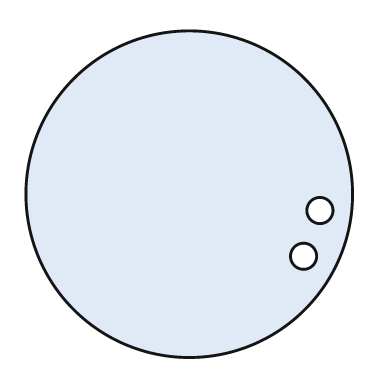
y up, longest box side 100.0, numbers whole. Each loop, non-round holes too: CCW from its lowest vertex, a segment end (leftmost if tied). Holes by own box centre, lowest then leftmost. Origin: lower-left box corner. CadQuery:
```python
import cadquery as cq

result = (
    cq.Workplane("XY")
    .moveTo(50.0, 50.0)
    .circle(50.0)
    .moveTo(85.0, 31.0)
    .circle(4.0)
    .moveTo(90.0, 45.0)
    .circle(4.0)
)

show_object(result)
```